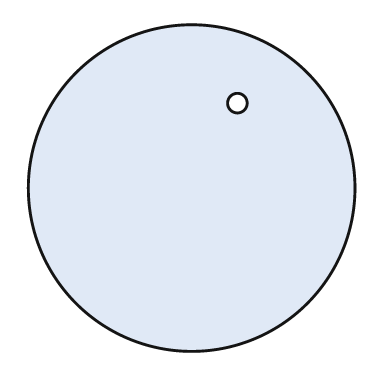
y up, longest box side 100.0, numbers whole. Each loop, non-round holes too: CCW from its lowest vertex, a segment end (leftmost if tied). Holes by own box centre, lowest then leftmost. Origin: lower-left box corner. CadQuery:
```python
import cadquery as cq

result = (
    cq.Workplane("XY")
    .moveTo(50.0, 50.0)
    .circle(50.0)
    .moveTo(64.0, 76.0)
    .circle(3.0)
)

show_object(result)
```